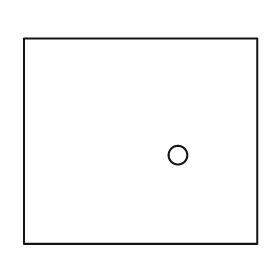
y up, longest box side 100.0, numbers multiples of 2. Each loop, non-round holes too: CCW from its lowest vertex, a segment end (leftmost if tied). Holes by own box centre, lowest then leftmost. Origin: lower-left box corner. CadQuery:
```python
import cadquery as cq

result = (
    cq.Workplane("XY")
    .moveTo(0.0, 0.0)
    .lineTo(100.0, 0.0)
    .lineTo(100.0, 88.0)
    .lineTo(0.0, 88.0)
    .close()
    .moveTo(66.0, 38.0)
    .circle(4.0)
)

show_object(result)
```